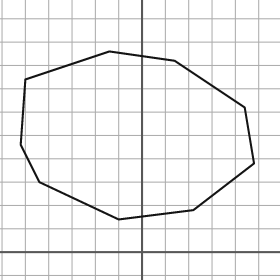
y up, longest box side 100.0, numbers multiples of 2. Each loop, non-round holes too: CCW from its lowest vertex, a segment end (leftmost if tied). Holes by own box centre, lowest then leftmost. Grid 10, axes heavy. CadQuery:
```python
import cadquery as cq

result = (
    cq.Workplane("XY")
    .moveTo(-10.0, 14.0)
    .lineTo(22.0, 18.0)
    .lineTo(48.0, 38.0)
    .lineTo(44.0, 62.0)
    .lineTo(14.0, 82.0)
    .lineTo(-14.0, 86.0)
    .lineTo(-50.0, 74.0)
    .lineTo(-52.0, 46.0)
    .lineTo(-44.0, 30.0)
    .close()
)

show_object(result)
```